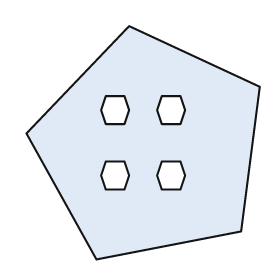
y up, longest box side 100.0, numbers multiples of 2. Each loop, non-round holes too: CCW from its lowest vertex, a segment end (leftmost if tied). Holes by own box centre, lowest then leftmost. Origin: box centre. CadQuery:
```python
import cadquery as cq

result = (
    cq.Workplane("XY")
    .moveTo(-20.0, -50.0)
    .lineTo(42.0, -38.0)
    .lineTo(50.0, 24.0)
    .lineTo(-6.0, 50.0)
    .lineTo(-50.0, 4.0)
    .close()
    .moveTo(-16.0, -20.0)
    .lineTo(-8.0, -20.0)
    .lineTo(-6.0, -14.0)
    .lineTo(-8.0, -8.0)
    .lineTo(-16.0, -8.0)
    .lineTo(-18.0, -14.0)
    .close()
    .moveTo(8.0, -20.0)
    .lineTo(16.0, -20.0)
    .lineTo(18.0, -14.0)
    .lineTo(16.0, -8.0)
    .lineTo(8.0, -8.0)
    .lineTo(6.0, -14.0)
    .close()
    .moveTo(-16.0, 8.0)
    .lineTo(-8.0, 8.0)
    .lineTo(-6.0, 14.0)
    .lineTo(-8.0, 20.0)
    .lineTo(-16.0, 20.0)
    .lineTo(-18.0, 14.0)
    .close()
    .moveTo(8.0, 8.0)
    .lineTo(16.0, 8.0)
    .lineTo(18.0, 14.0)
    .lineTo(16.0, 20.0)
    .lineTo(8.0, 20.0)
    .lineTo(6.0, 14.0)
    .close()
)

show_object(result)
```